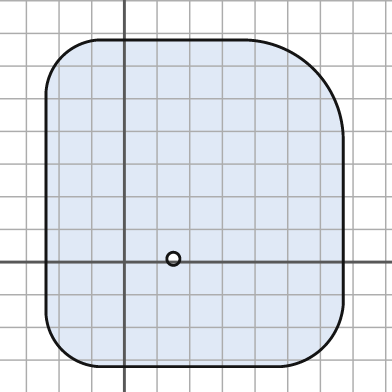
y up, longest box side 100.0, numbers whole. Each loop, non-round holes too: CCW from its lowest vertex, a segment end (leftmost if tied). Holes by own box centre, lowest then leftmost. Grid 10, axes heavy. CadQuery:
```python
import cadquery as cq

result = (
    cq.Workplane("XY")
    .moveTo(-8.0, -32.0)
    .lineTo(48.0, -32.0)
    .threePointArc((61.0, -26.0), (67.0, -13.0))
    .lineTo(67.0, 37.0)
    .threePointArc((58.0, 59.0), (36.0, 68.0))
    .lineTo(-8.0, 68.0)
    .threePointArc((-19.0, 63.0), (-24.0, 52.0))
    .lineTo(-24.0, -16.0)
    .threePointArc((-19.0, -27.0), (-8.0, -32.0))
    .close()
    .moveTo(15.0, 1.0)
    .circle(2.0)
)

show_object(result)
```